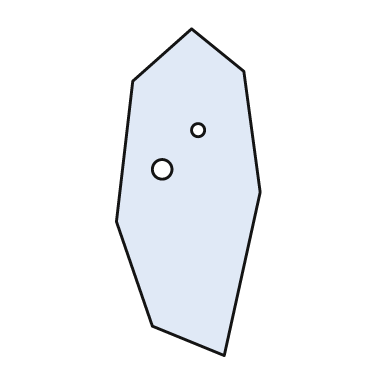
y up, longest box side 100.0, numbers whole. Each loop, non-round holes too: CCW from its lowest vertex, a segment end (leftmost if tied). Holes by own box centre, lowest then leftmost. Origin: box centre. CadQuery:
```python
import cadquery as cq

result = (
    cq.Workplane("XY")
    .moveTo(11.0, -50.0)
    .lineTo(22.0, 0.0)
    .lineTo(17.0, 37.0)
    .lineTo(1.0, 50.0)
    .lineTo(-17.0, 34.0)
    .lineTo(-22.0, -9.0)
    .lineTo(-11.0, -41.0)
    .close()
    .moveTo(-8.0, 7.0)
    .circle(3.0)
    .moveTo(3.0, 19.0)
    .circle(2.0)
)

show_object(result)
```